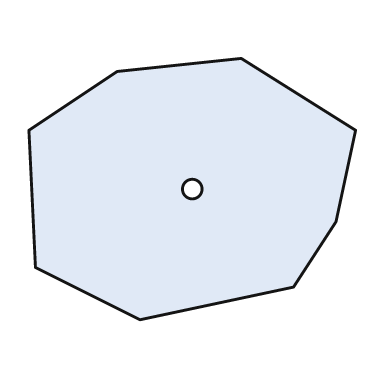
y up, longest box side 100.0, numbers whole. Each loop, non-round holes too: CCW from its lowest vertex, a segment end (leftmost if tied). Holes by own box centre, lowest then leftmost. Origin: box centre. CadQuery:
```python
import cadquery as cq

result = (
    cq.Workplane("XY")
    .moveTo(-16.0, -40.0)
    .lineTo(31.0, -30.0)
    .lineTo(44.0, -10.0)
    .lineTo(50.0, 18.0)
    .lineTo(15.0, 40.0)
    .lineTo(-23.0, 36.0)
    .lineTo(-50.0, 18.0)
    .lineTo(-48.0, -24.0)
    .close()
    .moveTo(0.0, 0.0)
    .circle(3.0)
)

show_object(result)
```